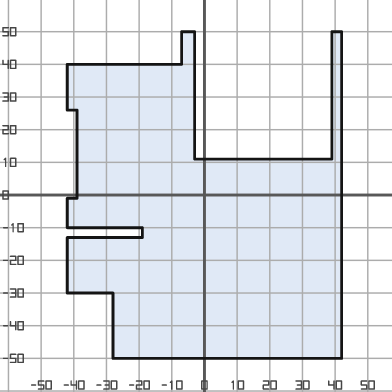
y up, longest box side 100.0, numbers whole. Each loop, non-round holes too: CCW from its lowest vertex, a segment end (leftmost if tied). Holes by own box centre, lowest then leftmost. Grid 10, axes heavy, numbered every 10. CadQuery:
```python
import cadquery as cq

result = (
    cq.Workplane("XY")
    .moveTo(-28.0, -50.0)
    .lineTo(42.0, -50.0)
    .lineTo(42.0, 50.0)
    .lineTo(39.0, 50.0)
    .lineTo(39.0, 11.0)
    .lineTo(-3.0, 11.0)
    .lineTo(-3.0, 50.0)
    .lineTo(-7.0, 50.0)
    .lineTo(-7.0, 40.0)
    .lineTo(-42.0, 40.0)
    .lineTo(-42.0, 26.0)
    .lineTo(-39.0, 26.0)
    .lineTo(-39.0, -1.0)
    .lineTo(-42.0, -1.0)
    .lineTo(-42.0, -10.0)
    .lineTo(-19.0, -10.0)
    .lineTo(-19.0, -13.0)
    .lineTo(-42.0, -13.0)
    .lineTo(-42.0, -30.0)
    .lineTo(-28.0, -30.0)
    .close()
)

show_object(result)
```